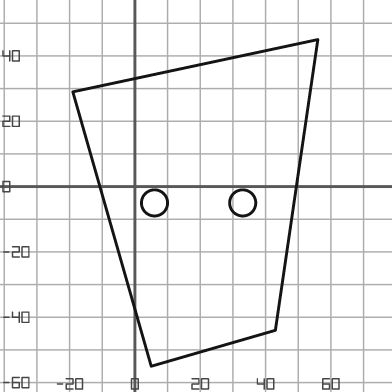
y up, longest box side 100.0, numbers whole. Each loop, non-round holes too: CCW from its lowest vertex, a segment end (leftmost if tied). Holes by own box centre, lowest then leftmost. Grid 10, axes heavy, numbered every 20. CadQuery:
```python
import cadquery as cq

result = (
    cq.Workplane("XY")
    .moveTo(5.0, -55.0)
    .lineTo(43.0, -44.0)
    .lineTo(56.0, 45.0)
    .lineTo(-19.0, 29.0)
    .close()
    .moveTo(6.0, -5.0)
    .circle(4.0)
    .moveTo(33.0, -5.0)
    .circle(4.0)
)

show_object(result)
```